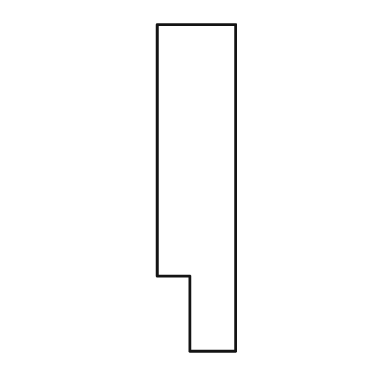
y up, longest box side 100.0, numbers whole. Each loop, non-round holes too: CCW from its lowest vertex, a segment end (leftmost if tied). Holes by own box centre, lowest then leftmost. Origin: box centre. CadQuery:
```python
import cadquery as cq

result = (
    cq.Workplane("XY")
    .moveTo(-2.0, -50.0)
    .lineTo(12.0, -50.0)
    .lineTo(12.0, 50.0)
    .lineTo(-12.0, 50.0)
    .lineTo(-12.0, -27.0)
    .lineTo(-2.0, -27.0)
    .close()
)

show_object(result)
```